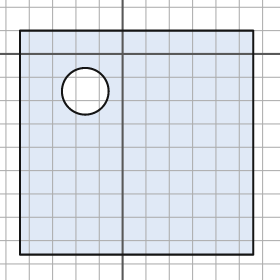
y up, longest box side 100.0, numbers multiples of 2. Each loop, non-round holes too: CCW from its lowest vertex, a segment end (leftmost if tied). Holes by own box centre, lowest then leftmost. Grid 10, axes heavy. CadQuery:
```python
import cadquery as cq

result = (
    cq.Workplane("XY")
    .moveTo(-44.0, -86.0)
    .lineTo(56.0, -86.0)
    .lineTo(56.0, 10.0)
    .lineTo(-44.0, 10.0)
    .close()
    .moveTo(-16.0, -16.0)
    .circle(10.0)
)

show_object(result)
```